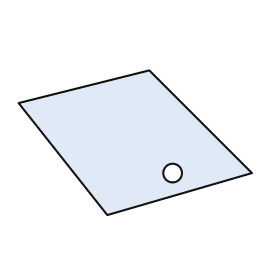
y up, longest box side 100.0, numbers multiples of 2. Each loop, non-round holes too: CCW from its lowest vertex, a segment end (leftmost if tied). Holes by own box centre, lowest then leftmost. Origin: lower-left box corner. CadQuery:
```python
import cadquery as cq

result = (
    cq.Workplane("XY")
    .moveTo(38.0, 0.0)
    .lineTo(100.0, 18.0)
    .lineTo(56.0, 62.0)
    .lineTo(0.0, 48.0)
    .close()
    .moveTo(66.0, 18.0)
    .circle(4.0)
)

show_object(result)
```